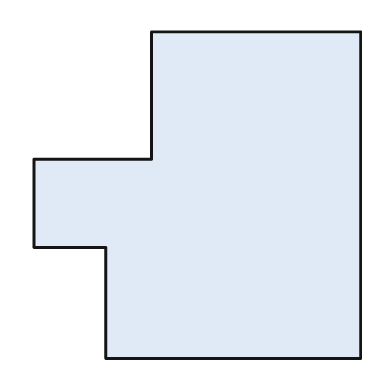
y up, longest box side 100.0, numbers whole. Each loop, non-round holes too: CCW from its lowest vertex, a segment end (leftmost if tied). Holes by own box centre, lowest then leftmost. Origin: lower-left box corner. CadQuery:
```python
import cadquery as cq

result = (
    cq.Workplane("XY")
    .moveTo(22.0, 0.0)
    .lineTo(100.0, 0.0)
    .lineTo(100.0, 100.0)
    .lineTo(36.0, 100.0)
    .lineTo(36.0, 61.0)
    .lineTo(0.0, 61.0)
    .lineTo(0.0, 34.0)
    .lineTo(22.0, 34.0)
    .close()
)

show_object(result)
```